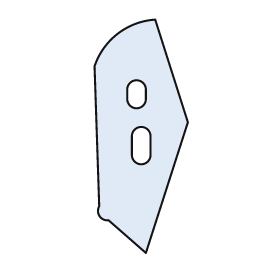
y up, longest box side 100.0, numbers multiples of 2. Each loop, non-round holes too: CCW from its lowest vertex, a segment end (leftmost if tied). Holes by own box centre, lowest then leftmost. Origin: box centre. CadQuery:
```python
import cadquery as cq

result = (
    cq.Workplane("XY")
    .moveTo(2.0, -50.0)
    .lineTo(20.0, 6.0)
    .lineTo(6.0, 50.0)
    .threePointArc((-10.0, 44.0), (-20.0, 30.0))
    .lineTo(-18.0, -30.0)
    .threePointArc((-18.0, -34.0), (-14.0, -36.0))
    .close()
    .moveTo(-4.0, -8.0)
    .threePointArc((0.0, -12.0), (4.0, -8.0))
    .lineTo(4.0, 0.0)
    .threePointArc((0.0, 4.0), (-4.0, 0.0))
    .close()
    .moveTo(-6.0, 16.0)
    .threePointArc((-2.0, 12.0), (2.0, 16.0))
    .lineTo(2.0, 20.0)
    .threePointArc((-2.0, 24.0), (-6.0, 20.0))
    .close()
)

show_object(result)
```